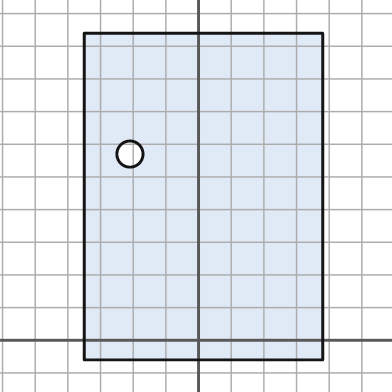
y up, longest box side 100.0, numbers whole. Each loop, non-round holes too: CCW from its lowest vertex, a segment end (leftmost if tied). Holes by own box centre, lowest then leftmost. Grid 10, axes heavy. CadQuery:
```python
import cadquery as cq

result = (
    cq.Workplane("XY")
    .moveTo(-35.0, -6.0)
    .lineTo(38.0, -6.0)
    .lineTo(38.0, 94.0)
    .lineTo(-35.0, 94.0)
    .close()
    .moveTo(-21.0, 57.0)
    .circle(4.0)
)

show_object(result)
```